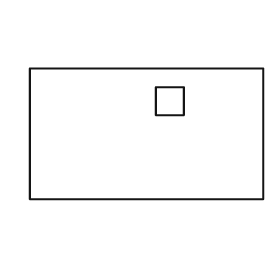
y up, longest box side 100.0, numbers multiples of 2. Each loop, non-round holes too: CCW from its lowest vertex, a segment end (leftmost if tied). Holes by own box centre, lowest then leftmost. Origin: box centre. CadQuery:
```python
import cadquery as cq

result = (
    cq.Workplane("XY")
    .moveTo(-50.0, -28.0)
    .lineTo(50.0, -28.0)
    .lineTo(50.0, 28.0)
    .lineTo(-50.0, 28.0)
    .close()
    .moveTo(4.0, 8.0)
    .lineTo(16.0, 8.0)
    .lineTo(16.0, 20.0)
    .lineTo(4.0, 20.0)
    .close()
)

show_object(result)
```